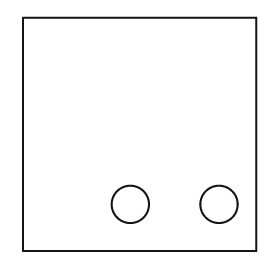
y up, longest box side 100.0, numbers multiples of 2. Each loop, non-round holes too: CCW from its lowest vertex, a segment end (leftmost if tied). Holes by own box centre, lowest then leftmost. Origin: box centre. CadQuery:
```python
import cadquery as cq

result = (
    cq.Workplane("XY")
    .moveTo(-50.0, -50.0)
    .lineTo(50.0, -50.0)
    .lineTo(50.0, 50.0)
    .lineTo(-50.0, 50.0)
    .close()
    .moveTo(-4.0, -30.0)
    .circle(8.0)
    .moveTo(34.0, -30.0)
    .circle(8.0)
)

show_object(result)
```